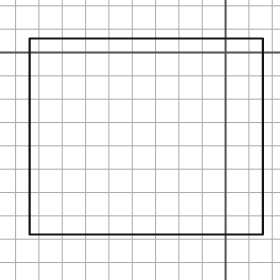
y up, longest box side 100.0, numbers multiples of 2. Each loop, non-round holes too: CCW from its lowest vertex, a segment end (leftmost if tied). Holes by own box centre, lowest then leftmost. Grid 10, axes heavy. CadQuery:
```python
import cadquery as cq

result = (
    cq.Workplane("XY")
    .moveTo(-84.0, -78.0)
    .lineTo(16.0, -78.0)
    .lineTo(16.0, 6.0)
    .lineTo(-84.0, 6.0)
    .close()
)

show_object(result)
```